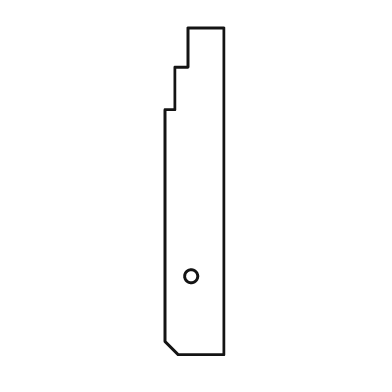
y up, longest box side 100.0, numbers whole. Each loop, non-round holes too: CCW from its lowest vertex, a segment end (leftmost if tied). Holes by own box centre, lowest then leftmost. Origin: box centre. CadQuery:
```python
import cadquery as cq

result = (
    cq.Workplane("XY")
    .moveTo(-5.0, -50.0)
    .lineTo(9.0, -50.0)
    .lineTo(9.0, 50.0)
    .lineTo(-2.0, 50.0)
    .lineTo(-2.0, 38.0)
    .lineTo(-6.0, 38.0)
    .lineTo(-6.0, 25.0)
    .lineTo(-9.0, 25.0)
    .lineTo(-9.0, -46.0)
    .close()
    .moveTo(-1.0, -26.0)
    .circle(2.0)
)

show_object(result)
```